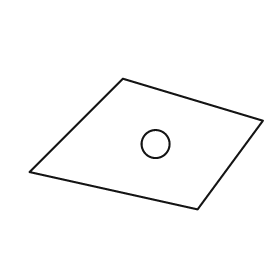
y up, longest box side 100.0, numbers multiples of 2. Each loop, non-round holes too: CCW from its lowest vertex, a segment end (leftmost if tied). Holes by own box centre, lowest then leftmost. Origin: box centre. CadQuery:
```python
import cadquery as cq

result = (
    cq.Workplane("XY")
    .moveTo(22.0, -28.0)
    .lineTo(50.0, 10.0)
    .lineTo(-10.0, 28.0)
    .lineTo(-50.0, -12.0)
    .close()
    .moveTo(4.0, 0.0)
    .circle(6.0)
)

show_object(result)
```